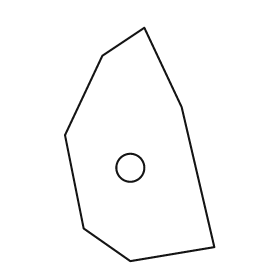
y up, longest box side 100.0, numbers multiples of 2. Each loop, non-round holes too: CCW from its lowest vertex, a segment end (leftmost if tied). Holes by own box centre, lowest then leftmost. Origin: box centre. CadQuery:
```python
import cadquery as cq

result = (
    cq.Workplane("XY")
    .moveTo(-4.0, -50.0)
    .lineTo(32.0, -44.0)
    .lineTo(18.0, 16.0)
    .lineTo(2.0, 50.0)
    .lineTo(-16.0, 38.0)
    .lineTo(-32.0, 4.0)
    .lineTo(-24.0, -36.0)
    .close()
    .moveTo(-4.0, -10.0)
    .circle(6.0)
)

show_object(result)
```